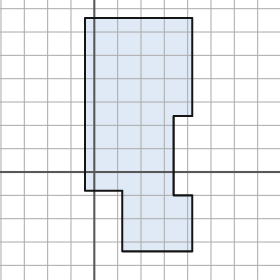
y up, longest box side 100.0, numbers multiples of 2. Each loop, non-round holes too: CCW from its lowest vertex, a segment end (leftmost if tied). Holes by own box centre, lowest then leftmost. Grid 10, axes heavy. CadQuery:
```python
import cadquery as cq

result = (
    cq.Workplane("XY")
    .moveTo(12.0, -34.0)
    .lineTo(42.0, -34.0)
    .lineTo(42.0, -10.0)
    .lineTo(34.0, -10.0)
    .lineTo(34.0, 24.0)
    .lineTo(42.0, 24.0)
    .lineTo(42.0, 66.0)
    .lineTo(-4.0, 66.0)
    .lineTo(-4.0, -8.0)
    .lineTo(12.0, -8.0)
    .close()
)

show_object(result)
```